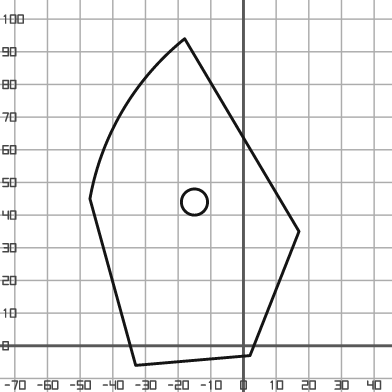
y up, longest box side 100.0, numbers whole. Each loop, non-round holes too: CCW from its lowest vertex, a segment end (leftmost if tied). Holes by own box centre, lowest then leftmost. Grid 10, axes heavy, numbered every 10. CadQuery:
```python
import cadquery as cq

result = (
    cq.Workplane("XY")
    .moveTo(-33.0, -6.0)
    .lineTo(2.0, -3.0)
    .lineTo(17.0, 35.0)
    .lineTo(-18.0, 94.0)
    .threePointArc((-37.0, 72.0), (-47.0, 45.0))
    .close()
    .moveTo(-15.0, 44.0)
    .circle(4.0)
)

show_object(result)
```